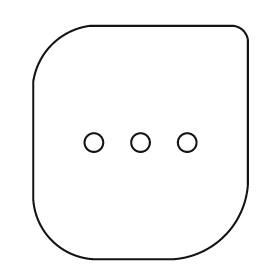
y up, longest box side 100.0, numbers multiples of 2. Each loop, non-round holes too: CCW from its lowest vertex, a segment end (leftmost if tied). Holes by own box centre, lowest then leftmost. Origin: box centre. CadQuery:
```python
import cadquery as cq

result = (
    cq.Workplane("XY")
    .moveTo(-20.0, -50.0)
    .lineTo(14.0, -50.0)
    .threePointArc((36.0, -40.0), (46.0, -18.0))
    .lineTo(46.0, 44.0)
    .threePointArc((44.0, 48.0), (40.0, 50.0))
    .lineTo(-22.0, 50.0)
    .threePointArc((-38.0, 42.0), (-46.0, 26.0))
    .lineTo(-46.0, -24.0)
    .threePointArc((-38.0, -42.0), (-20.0, -50.0))
    .close()
    .moveTo(-20.0, 0.0)
    .circle(4.0)
    .moveTo(0.0, 0.0)
    .circle(4.0)
    .moveTo(20.0, 0.0)
    .circle(4.0)
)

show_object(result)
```